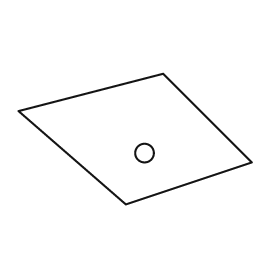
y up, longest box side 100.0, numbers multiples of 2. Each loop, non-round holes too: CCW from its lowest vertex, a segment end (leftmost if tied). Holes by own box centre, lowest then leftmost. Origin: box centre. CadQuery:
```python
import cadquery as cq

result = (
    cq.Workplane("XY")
    .moveTo(-4.0, -28.0)
    .lineTo(50.0, -10.0)
    .lineTo(12.0, 28.0)
    .lineTo(-50.0, 12.0)
    .close()
    .moveTo(4.0, -6.0)
    .circle(4.0)
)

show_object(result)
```